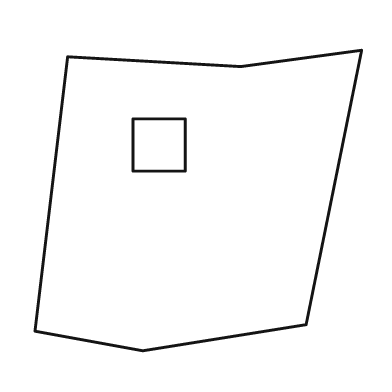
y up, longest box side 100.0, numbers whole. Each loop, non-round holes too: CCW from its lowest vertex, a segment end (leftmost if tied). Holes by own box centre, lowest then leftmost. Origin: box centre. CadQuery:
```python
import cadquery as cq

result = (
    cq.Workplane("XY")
    .moveTo(-17.0, -46.0)
    .lineTo(33.0, -38.0)
    .lineTo(50.0, 46.0)
    .lineTo(13.0, 41.0)
    .lineTo(-40.0, 44.0)
    .lineTo(-50.0, -40.0)
    .close()
    .moveTo(-20.0, 9.0)
    .lineTo(-4.0, 9.0)
    .lineTo(-4.0, 25.0)
    .lineTo(-20.0, 25.0)
    .close()
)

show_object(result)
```